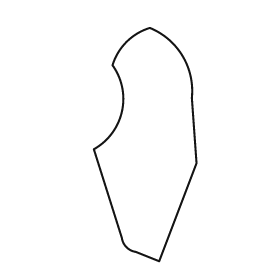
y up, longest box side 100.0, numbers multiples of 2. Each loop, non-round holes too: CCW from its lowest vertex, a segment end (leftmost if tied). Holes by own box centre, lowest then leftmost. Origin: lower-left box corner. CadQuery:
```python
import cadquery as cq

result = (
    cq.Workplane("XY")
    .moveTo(28.0, 0.0)
    .lineTo(44.0, 42.0)
    .lineTo(42.0, 70.0)
    .threePointArc((38.0, 88.0), (24.0, 100.0))
    .threePointArc((14.0, 94.0), (8.0, 84.0))
    .threePointArc((12.0, 64.0), (0.0, 48.0))
    .lineTo(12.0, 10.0)
    .threePointArc((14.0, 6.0), (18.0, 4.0))
    .close()
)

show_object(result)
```